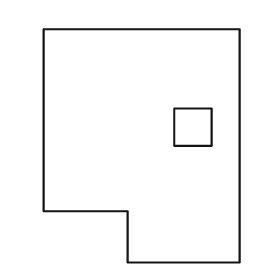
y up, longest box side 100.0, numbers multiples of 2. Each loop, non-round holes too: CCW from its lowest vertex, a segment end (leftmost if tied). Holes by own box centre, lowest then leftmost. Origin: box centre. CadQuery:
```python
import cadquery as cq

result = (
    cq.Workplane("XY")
    .moveTo(-6.0, -50.0)
    .lineTo(42.0, -50.0)
    .lineTo(42.0, 50.0)
    .lineTo(-42.0, 50.0)
    .lineTo(-42.0, -28.0)
    .lineTo(-6.0, -28.0)
    .close()
    .moveTo(14.0, 0.0)
    .lineTo(30.0, 0.0)
    .lineTo(30.0, 16.0)
    .lineTo(14.0, 16.0)
    .close()
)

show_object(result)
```